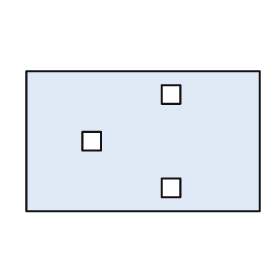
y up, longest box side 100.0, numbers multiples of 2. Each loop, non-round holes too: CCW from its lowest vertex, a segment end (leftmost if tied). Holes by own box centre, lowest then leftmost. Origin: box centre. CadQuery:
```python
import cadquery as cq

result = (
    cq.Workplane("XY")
    .moveTo(-50.0, -30.0)
    .lineTo(50.0, -30.0)
    .lineTo(50.0, 30.0)
    .lineTo(-50.0, 30.0)
    .close()
    .moveTo(8.0, -24.0)
    .lineTo(16.0, -24.0)
    .lineTo(16.0, -16.0)
    .lineTo(8.0, -16.0)
    .close()
    .moveTo(-26.0, -4.0)
    .lineTo(-18.0, -4.0)
    .lineTo(-18.0, 4.0)
    .lineTo(-26.0, 4.0)
    .close()
    .moveTo(8.0, 16.0)
    .lineTo(16.0, 16.0)
    .lineTo(16.0, 24.0)
    .lineTo(8.0, 24.0)
    .close()
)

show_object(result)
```